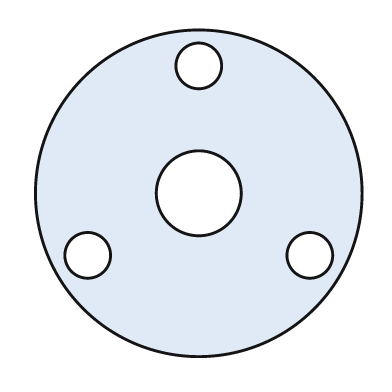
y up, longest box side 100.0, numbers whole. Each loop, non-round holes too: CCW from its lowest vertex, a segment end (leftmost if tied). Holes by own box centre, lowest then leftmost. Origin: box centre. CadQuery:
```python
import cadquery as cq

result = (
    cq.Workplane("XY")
    .moveTo(0.0, 0.0)
    .circle(50.0)
    .moveTo(-34.0, -19.0)
    .circle(7.0)
    .moveTo(34.0, -19.0)
    .circle(7.0)
    .moveTo(0.0, 0.0)
    .circle(13.0)
    .moveTo(0.0, 39.0)
    .circle(7.0)
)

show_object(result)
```